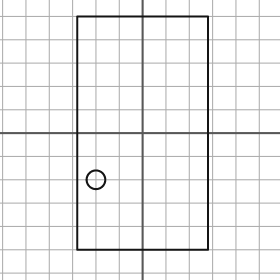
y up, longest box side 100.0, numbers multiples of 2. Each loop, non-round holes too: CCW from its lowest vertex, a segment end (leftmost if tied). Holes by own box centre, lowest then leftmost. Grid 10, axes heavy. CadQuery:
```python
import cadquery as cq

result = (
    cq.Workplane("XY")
    .moveTo(-28.0, -50.0)
    .lineTo(28.0, -50.0)
    .lineTo(28.0, 50.0)
    .lineTo(-28.0, 50.0)
    .close()
    .moveTo(-20.0, -20.0)
    .circle(4.0)
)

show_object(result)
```